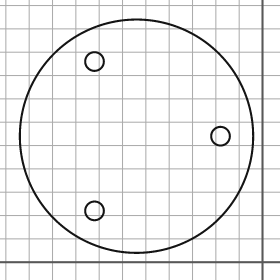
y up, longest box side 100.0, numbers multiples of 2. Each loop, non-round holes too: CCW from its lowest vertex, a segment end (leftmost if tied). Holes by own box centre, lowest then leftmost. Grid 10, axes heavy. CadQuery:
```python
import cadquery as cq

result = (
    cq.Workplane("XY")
    .moveTo(-54.0, 54.0)
    .circle(50.0)
    .moveTo(-72.0, 22.0)
    .circle(4.0)
    .moveTo(-18.0, 54.0)
    .circle(4.0)
    .moveTo(-72.0, 86.0)
    .circle(4.0)
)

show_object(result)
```